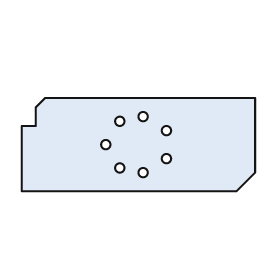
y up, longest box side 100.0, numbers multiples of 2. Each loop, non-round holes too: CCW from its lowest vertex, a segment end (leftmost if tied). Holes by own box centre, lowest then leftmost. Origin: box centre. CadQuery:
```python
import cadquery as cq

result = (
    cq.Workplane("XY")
    .moveTo(-50.0, -20.0)
    .lineTo(42.0, -20.0)
    .lineTo(50.0, -12.0)
    .lineTo(50.0, 20.0)
    .lineTo(-40.0, 20.0)
    .lineTo(-44.0, 16.0)
    .lineTo(-44.0, 8.0)
    .lineTo(-50.0, 8.0)
    .close()
    .moveTo(2.0, -12.0)
    .circle(2.0)
    .moveTo(-8.0, -10.0)
    .circle(2.0)
    .moveTo(12.0, -6.0)
    .circle(2.0)
    .moveTo(-14.0, 0.0)
    .circle(2.0)
    .moveTo(12.0, 6.0)
    .circle(2.0)
    .moveTo(-8.0, 10.0)
    .circle(2.0)
    .moveTo(2.0, 12.0)
    .circle(2.0)
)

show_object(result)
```